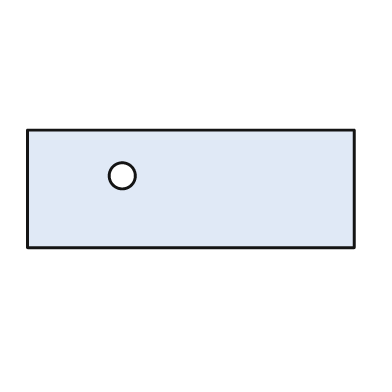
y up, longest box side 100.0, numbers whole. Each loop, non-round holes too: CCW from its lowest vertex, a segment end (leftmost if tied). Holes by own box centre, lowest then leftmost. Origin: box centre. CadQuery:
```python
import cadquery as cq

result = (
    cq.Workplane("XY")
    .moveTo(-50.0, -18.0)
    .lineTo(50.0, -18.0)
    .lineTo(50.0, 18.0)
    .lineTo(-50.0, 18.0)
    .close()
    .moveTo(-21.0, 4.0)
    .circle(4.0)
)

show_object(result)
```